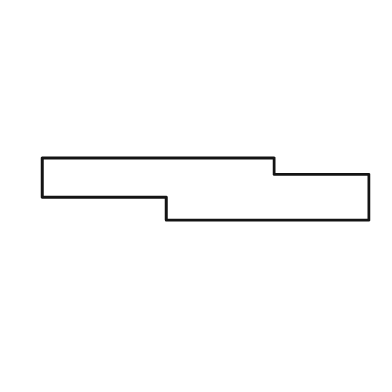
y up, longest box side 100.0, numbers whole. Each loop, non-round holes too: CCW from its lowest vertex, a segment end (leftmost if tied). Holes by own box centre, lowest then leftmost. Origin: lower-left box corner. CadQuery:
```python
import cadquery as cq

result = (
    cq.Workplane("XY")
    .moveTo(38.0, 0.0)
    .lineTo(100.0, 0.0)
    .lineTo(100.0, 14.0)
    .lineTo(71.0, 14.0)
    .lineTo(71.0, 19.0)
    .lineTo(0.0, 19.0)
    .lineTo(0.0, 7.0)
    .lineTo(38.0, 7.0)
    .close()
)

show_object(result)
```